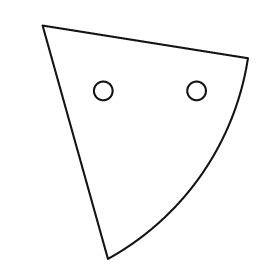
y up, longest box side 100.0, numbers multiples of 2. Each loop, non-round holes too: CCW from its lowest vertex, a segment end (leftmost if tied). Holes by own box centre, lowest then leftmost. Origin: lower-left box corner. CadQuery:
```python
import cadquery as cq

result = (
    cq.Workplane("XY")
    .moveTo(28.0, 0.0)
    .threePointArc((68.0, 36.0), (88.0, 86.0))
    .lineTo(0.0, 100.0)
    .close()
    .moveTo(26.0, 72.0)
    .circle(4.0)
    .moveTo(66.0, 72.0)
    .circle(4.0)
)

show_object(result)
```